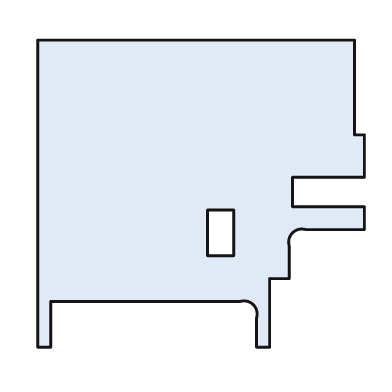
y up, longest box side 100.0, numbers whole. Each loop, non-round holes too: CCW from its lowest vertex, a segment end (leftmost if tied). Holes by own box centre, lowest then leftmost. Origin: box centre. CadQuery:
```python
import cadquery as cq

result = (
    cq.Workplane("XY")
    .moveTo(-50.0, -47.0)
    .lineTo(-46.0, -47.0)
    .lineTo(-46.0, -33.0)
    .lineTo(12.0, -33.0)
    .threePointArc((16.0, -34.0), (17.0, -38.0))
    .lineTo(17.0, -47.0)
    .lineTo(21.0, -47.0)
    .lineTo(21.0, -26.0)
    .lineTo(27.0, -26.0)
    .lineTo(27.0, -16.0)
    .threePointArc((28.0, -12.0), (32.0, -11.0))
    .lineTo(50.0, -11.0)
    .lineTo(50.0, -4.0)
    .lineTo(28.0, -4.0)
    .lineTo(28.0, 5.0)
    .lineTo(50.0, 5.0)
    .lineTo(50.0, 18.0)
    .lineTo(47.0, 18.0)
    .lineTo(47.0, 47.0)
    .lineTo(-50.0, 47.0)
    .close()
    .moveTo(2.0, -19.0)
    .lineTo(10.0, -19.0)
    .lineTo(10.0, -5.0)
    .lineTo(2.0, -5.0)
    .close()
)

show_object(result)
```